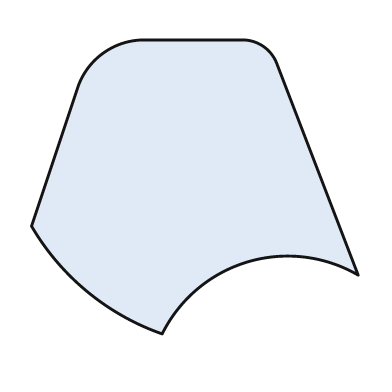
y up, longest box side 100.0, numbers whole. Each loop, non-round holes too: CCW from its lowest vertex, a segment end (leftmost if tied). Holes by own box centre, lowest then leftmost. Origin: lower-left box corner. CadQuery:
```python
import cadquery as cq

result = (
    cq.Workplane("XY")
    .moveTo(40.0, 0.0)
    .threePointArc((66.0, 22.0), (100.0, 18.0))
    .lineTo(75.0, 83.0)
    .threePointArc((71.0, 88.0), (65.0, 90.0))
    .lineTo(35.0, 90.0)
    .threePointArc((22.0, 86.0), (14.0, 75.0))
    .lineTo(0.0, 33.0)
    .threePointArc((17.0, 13.0), (40.0, 0.0))
    .close()
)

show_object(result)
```